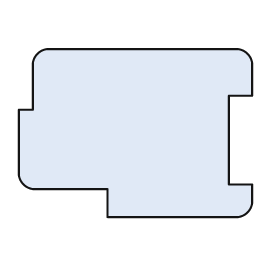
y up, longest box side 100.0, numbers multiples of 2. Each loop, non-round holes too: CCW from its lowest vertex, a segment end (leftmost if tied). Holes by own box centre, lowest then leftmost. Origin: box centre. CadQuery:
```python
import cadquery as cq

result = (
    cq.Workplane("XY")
    .moveTo(-12.0, -36.0)
    .lineTo(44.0, -36.0)
    .threePointArc((48.0, -34.0), (50.0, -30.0))
    .lineTo(50.0, -22.0)
    .lineTo(40.0, -22.0)
    .lineTo(40.0, 16.0)
    .lineTo(50.0, 16.0)
    .lineTo(50.0, 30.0)
    .threePointArc((48.0, 34.0), (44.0, 36.0))
    .lineTo(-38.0, 36.0)
    .threePointArc((-42.0, 34.0), (-44.0, 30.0))
    .lineTo(-44.0, 10.0)
    .lineTo(-50.0, 10.0)
    .lineTo(-50.0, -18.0)
    .threePointArc((-48.0, -22.0), (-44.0, -24.0))
    .lineTo(-12.0, -24.0)
    .close()
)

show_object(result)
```